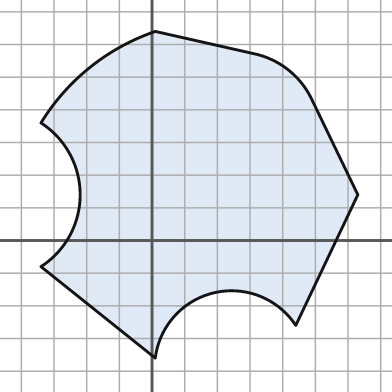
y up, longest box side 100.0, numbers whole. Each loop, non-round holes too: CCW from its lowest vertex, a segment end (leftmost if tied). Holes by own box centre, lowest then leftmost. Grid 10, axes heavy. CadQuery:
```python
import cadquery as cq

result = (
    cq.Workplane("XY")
    .moveTo(1.0, -36.0)
    .threePointArc((19.0, -16.0), (44.0, -26.0))
    .lineTo(63.0, 14.0)
    .lineTo(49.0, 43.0)
    .threePointArc((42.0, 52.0), (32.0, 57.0))
    .lineTo(1.0, 64.0)
    .threePointArc((-19.0, 53.0), (-34.0, 36.0))
    .threePointArc((-22.0, 14.0), (-34.0, -8.0))
    .close()
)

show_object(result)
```